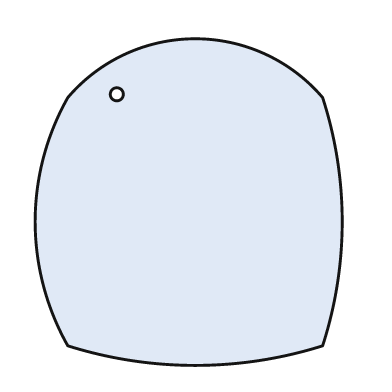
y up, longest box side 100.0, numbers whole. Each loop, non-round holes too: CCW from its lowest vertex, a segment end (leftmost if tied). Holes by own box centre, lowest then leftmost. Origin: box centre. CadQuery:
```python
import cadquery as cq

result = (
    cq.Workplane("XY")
    .moveTo(-37.0, -44.0)
    .threePointArc((2.0, -50.0), (41.0, -44.0))
    .threePointArc((47.0, -6.0), (41.0, 32.0))
    .threePointArc((2.0, 50.0), (-37.0, 32.0))
    .threePointArc((-47.0, -6.0), (-37.0, -44.0))
    .close()
    .moveTo(-22.0, 33.0)
    .circle(2.0)
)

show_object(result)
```